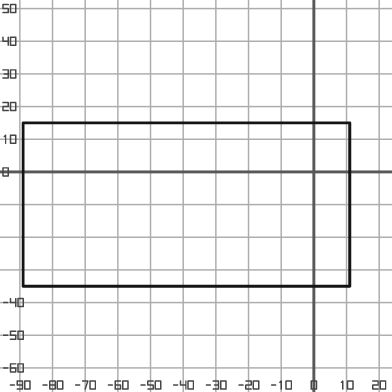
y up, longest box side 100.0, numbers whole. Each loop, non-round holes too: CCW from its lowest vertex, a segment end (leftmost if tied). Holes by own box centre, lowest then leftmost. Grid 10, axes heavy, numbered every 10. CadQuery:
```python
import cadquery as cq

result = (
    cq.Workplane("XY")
    .moveTo(-89.0, -35.0)
    .lineTo(11.0, -35.0)
    .lineTo(11.0, 15.0)
    .lineTo(-89.0, 15.0)
    .close()
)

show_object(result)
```